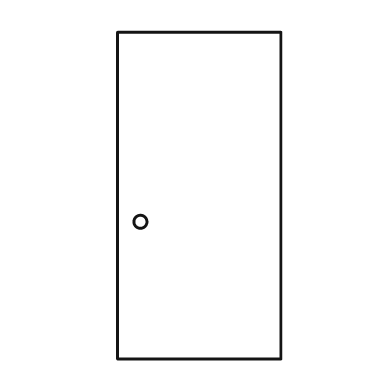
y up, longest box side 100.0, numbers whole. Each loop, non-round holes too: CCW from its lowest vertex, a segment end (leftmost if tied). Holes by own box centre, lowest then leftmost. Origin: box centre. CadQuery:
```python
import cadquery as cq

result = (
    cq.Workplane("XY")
    .moveTo(-25.0, -50.0)
    .lineTo(25.0, -50.0)
    .lineTo(25.0, 50.0)
    .lineTo(-25.0, 50.0)
    .close()
    .moveTo(-18.0, -8.0)
    .circle(2.0)
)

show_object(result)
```